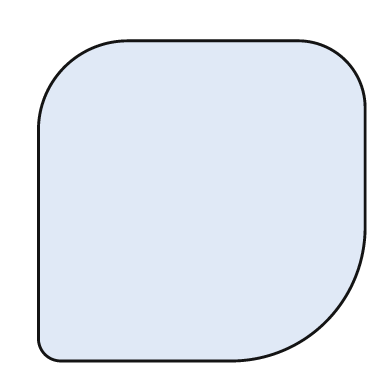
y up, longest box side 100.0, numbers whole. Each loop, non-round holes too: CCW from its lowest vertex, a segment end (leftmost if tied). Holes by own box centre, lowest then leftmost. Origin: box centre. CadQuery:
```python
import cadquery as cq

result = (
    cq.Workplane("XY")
    .moveTo(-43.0, -49.0)
    .lineTo(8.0, -49.0)
    .threePointArc((38.0, -37.0), (50.0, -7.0))
    .lineTo(50.0, 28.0)
    .threePointArc((44.0, 43.0), (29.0, 49.0))
    .lineTo(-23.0, 49.0)
    .threePointArc((-42.0, 41.0), (-50.0, 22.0))
    .lineTo(-50.0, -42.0)
    .threePointArc((-48.0, -47.0), (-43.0, -49.0))
    .close()
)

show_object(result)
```